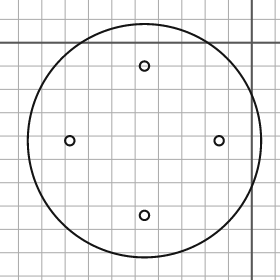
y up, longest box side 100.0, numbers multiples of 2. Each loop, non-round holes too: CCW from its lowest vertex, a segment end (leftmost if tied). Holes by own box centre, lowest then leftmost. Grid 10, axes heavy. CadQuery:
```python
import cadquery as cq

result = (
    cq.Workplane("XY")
    .moveTo(-46.0, -42.0)
    .circle(50.0)
    .moveTo(-46.0, -74.0)
    .circle(2.0)
    .moveTo(-78.0, -42.0)
    .circle(2.0)
    .moveTo(-14.0, -42.0)
    .circle(2.0)
    .moveTo(-46.0, -10.0)
    .circle(2.0)
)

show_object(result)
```